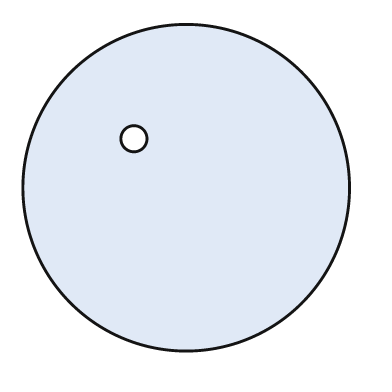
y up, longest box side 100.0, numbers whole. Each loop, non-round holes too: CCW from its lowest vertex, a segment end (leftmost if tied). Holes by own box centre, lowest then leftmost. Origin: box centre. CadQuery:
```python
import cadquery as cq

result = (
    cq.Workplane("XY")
    .moveTo(0.0, 0.0)
    .circle(50.0)
    .moveTo(-16.0, 15.0)
    .circle(4.0)
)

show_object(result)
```